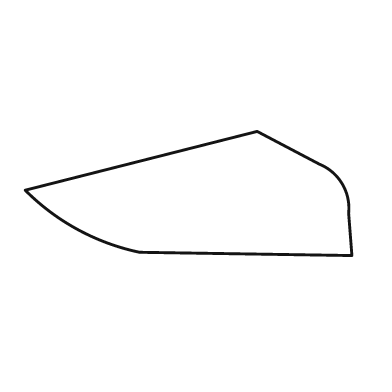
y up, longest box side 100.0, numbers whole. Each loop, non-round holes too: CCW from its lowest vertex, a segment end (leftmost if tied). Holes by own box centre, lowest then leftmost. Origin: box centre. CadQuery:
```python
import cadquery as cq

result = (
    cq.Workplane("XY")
    .moveTo(50.0, -19.0)
    .lineTo(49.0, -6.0)
    .threePointArc((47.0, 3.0), (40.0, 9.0))
    .lineTo(21.0, 19.0)
    .lineTo(-50.0, 1.0)
    .threePointArc((-34.0, -11.0), (-15.0, -18.0))
    .close()
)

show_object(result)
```